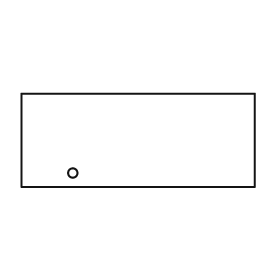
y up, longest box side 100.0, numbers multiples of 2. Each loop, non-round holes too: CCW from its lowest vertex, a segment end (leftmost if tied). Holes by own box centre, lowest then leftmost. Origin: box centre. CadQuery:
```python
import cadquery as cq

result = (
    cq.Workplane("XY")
    .moveTo(-50.0, -20.0)
    .lineTo(50.0, -20.0)
    .lineTo(50.0, 20.0)
    .lineTo(-50.0, 20.0)
    .close()
    .moveTo(-28.0, -14.0)
    .circle(2.0)
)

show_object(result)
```